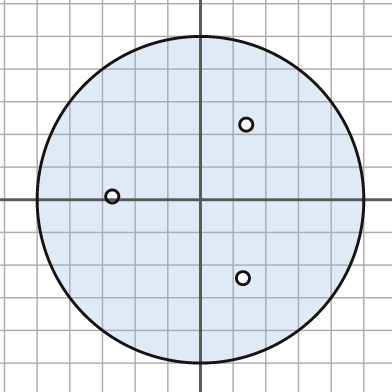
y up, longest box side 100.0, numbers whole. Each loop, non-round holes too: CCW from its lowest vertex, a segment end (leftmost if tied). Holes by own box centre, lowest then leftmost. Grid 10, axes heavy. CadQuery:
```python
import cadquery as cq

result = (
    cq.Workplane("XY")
    .moveTo(0.0, 0.0)
    .circle(50.0)
    .moveTo(13.0, -24.0)
    .circle(2.0)
    .moveTo(-27.0, 1.0)
    .circle(2.0)
    .moveTo(14.0, 23.0)
    .circle(2.0)
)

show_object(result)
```